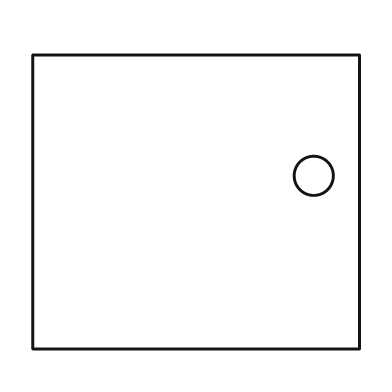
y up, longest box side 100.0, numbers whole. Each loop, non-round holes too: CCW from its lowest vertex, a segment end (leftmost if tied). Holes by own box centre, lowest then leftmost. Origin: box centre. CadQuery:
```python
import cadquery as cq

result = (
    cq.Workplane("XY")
    .moveTo(-50.0, -45.0)
    .lineTo(50.0, -45.0)
    .lineTo(50.0, 45.0)
    .lineTo(-50.0, 45.0)
    .close()
    .moveTo(36.0, 8.0)
    .circle(6.0)
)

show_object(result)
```